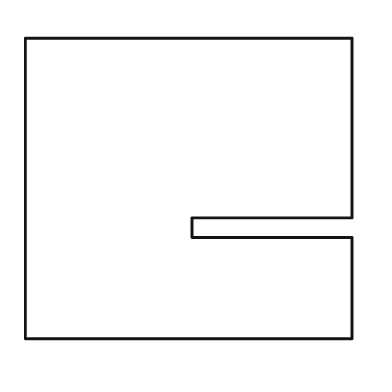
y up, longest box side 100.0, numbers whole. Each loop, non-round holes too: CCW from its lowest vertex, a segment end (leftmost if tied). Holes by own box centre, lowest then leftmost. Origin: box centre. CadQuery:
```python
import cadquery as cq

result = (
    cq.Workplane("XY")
    .moveTo(-50.0, -46.0)
    .lineTo(50.0, -46.0)
    .lineTo(50.0, -15.0)
    .lineTo(1.0, -15.0)
    .lineTo(1.0, -9.0)
    .lineTo(50.0, -9.0)
    .lineTo(50.0, 46.0)
    .lineTo(-50.0, 46.0)
    .close()
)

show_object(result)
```